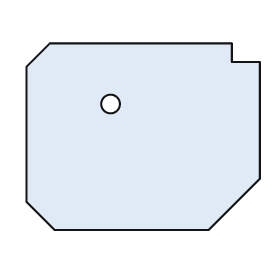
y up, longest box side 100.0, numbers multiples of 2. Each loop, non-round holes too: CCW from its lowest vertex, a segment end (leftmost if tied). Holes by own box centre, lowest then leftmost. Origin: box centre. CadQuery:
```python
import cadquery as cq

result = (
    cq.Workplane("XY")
    .moveTo(-38.0, -40.0)
    .lineTo(28.0, -40.0)
    .lineTo(50.0, -18.0)
    .lineTo(50.0, 32.0)
    .lineTo(38.0, 32.0)
    .lineTo(38.0, 40.0)
    .lineTo(-40.0, 40.0)
    .lineTo(-50.0, 30.0)
    .lineTo(-50.0, -28.0)
    .close()
    .moveTo(-14.0, 14.0)
    .circle(4.0)
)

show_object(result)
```